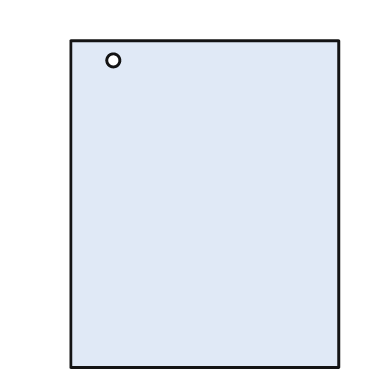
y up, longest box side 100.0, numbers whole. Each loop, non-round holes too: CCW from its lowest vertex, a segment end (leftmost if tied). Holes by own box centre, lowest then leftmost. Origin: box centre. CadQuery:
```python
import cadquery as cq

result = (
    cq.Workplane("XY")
    .moveTo(-41.0, -50.0)
    .lineTo(41.0, -50.0)
    .lineTo(41.0, 50.0)
    .lineTo(-41.0, 50.0)
    .close()
    .moveTo(-28.0, 44.0)
    .circle(2.0)
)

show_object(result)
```